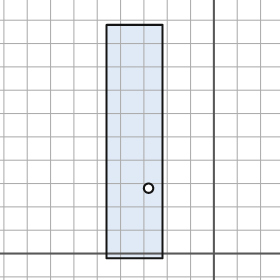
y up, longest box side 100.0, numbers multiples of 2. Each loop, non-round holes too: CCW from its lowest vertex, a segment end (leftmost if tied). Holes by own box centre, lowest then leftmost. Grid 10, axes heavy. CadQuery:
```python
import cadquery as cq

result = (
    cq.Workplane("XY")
    .moveTo(-46.0, -2.0)
    .lineTo(-22.0, -2.0)
    .lineTo(-22.0, 98.0)
    .lineTo(-46.0, 98.0)
    .close()
    .moveTo(-28.0, 28.0)
    .circle(2.0)
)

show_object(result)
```